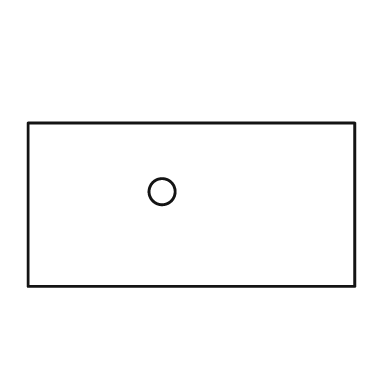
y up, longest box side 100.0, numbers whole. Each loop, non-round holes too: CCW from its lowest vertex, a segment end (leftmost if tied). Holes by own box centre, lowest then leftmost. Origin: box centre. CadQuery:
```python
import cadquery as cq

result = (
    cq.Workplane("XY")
    .moveTo(-50.0, -25.0)
    .lineTo(50.0, -25.0)
    .lineTo(50.0, 25.0)
    .lineTo(-50.0, 25.0)
    .close()
    .moveTo(-9.0, 4.0)
    .circle(4.0)
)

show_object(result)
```